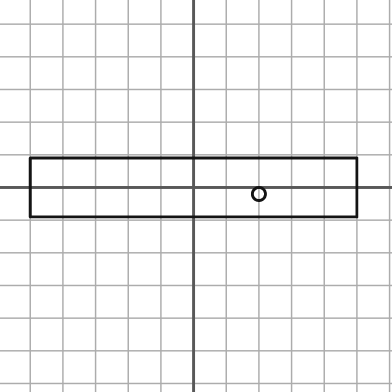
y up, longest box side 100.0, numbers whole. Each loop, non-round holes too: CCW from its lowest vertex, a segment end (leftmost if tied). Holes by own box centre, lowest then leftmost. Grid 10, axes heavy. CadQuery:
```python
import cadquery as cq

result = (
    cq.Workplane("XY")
    .moveTo(-50.0, -9.0)
    .lineTo(50.0, -9.0)
    .lineTo(50.0, 9.0)
    .lineTo(-50.0, 9.0)
    .close()
    .moveTo(20.0, -2.0)
    .circle(2.0)
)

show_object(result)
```